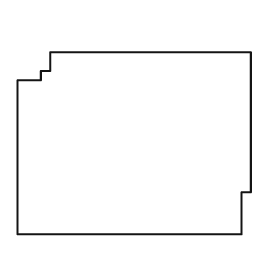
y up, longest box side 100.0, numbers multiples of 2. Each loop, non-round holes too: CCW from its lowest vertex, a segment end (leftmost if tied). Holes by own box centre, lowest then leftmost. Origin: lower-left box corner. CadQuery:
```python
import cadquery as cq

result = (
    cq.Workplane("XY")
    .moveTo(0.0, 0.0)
    .lineTo(96.0, 0.0)
    .lineTo(96.0, 18.0)
    .lineTo(100.0, 18.0)
    .lineTo(100.0, 78.0)
    .lineTo(14.0, 78.0)
    .lineTo(14.0, 70.0)
    .lineTo(10.0, 70.0)
    .lineTo(10.0, 66.0)
    .lineTo(0.0, 66.0)
    .close()
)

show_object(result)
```